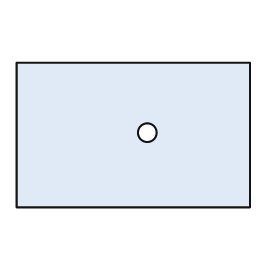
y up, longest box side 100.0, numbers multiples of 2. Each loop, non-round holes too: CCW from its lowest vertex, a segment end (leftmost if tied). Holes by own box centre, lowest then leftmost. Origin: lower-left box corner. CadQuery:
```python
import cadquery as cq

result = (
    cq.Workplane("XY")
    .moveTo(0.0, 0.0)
    .lineTo(100.0, 0.0)
    .lineTo(100.0, 62.0)
    .lineTo(0.0, 62.0)
    .close()
    .moveTo(56.0, 32.0)
    .circle(4.0)
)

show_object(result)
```